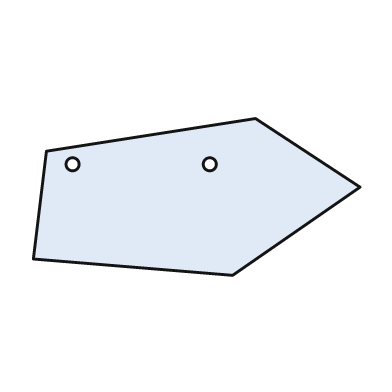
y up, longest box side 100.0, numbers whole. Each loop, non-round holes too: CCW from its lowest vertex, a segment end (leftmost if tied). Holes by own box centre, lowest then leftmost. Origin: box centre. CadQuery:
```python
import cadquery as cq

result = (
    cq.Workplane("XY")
    .moveTo(11.0, -24.0)
    .lineTo(50.0, 3.0)
    .lineTo(18.0, 24.0)
    .lineTo(-46.0, 14.0)
    .lineTo(-50.0, -19.0)
    .close()
    .moveTo(-38.0, 10.0)
    .circle(2.0)
    .moveTo(4.0, 10.0)
    .circle(2.0)
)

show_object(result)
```